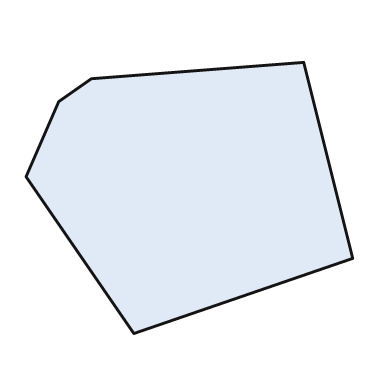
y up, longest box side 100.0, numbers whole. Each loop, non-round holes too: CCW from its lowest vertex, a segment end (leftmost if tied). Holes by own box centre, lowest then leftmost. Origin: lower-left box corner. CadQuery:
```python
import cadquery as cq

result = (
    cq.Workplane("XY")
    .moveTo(33.0, 0.0)
    .lineTo(100.0, 23.0)
    .lineTo(85.0, 83.0)
    .lineTo(20.0, 78.0)
    .lineTo(10.0, 71.0)
    .lineTo(0.0, 48.0)
    .close()
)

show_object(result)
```